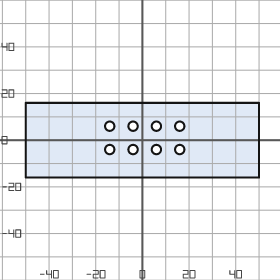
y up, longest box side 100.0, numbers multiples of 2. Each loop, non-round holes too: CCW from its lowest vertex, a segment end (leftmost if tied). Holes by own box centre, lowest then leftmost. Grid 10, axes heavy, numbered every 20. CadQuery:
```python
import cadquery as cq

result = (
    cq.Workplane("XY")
    .moveTo(-50.0, -16.0)
    .lineTo(50.0, -16.0)
    .lineTo(50.0, 16.0)
    .lineTo(-50.0, 16.0)
    .close()
    .moveTo(-14.0, -4.0)
    .circle(2.0)
    .moveTo(-4.0, -4.0)
    .circle(2.0)
    .moveTo(6.0, -4.0)
    .circle(2.0)
    .moveTo(16.0, -4.0)
    .circle(2.0)
    .moveTo(-14.0, 6.0)
    .circle(2.0)
    .moveTo(-4.0, 6.0)
    .circle(2.0)
    .moveTo(6.0, 6.0)
    .circle(2.0)
    .moveTo(16.0, 6.0)
    .circle(2.0)
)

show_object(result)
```